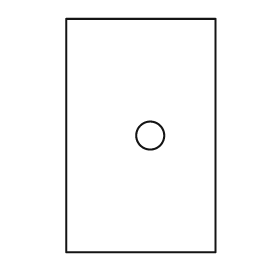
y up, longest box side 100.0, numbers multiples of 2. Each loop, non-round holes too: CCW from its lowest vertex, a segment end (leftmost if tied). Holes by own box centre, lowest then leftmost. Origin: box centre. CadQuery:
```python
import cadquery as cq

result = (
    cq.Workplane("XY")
    .moveTo(-32.0, -50.0)
    .lineTo(32.0, -50.0)
    .lineTo(32.0, 50.0)
    .lineTo(-32.0, 50.0)
    .close()
    .moveTo(4.0, 0.0)
    .circle(6.0)
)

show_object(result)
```